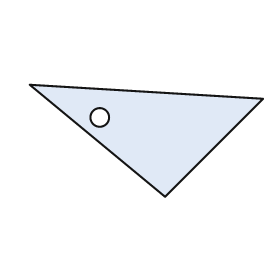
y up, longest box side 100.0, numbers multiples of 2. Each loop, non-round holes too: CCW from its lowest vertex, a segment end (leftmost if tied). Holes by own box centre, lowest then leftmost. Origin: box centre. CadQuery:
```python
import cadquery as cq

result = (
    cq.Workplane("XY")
    .moveTo(8.0, -24.0)
    .lineTo(50.0, 18.0)
    .lineTo(-50.0, 24.0)
    .close()
    .moveTo(-20.0, 10.0)
    .circle(4.0)
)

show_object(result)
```